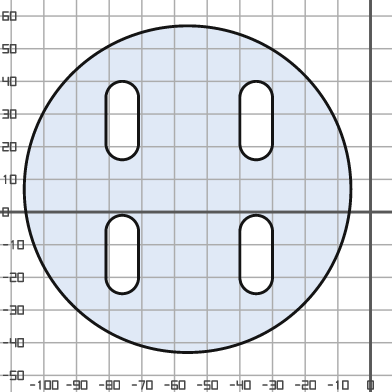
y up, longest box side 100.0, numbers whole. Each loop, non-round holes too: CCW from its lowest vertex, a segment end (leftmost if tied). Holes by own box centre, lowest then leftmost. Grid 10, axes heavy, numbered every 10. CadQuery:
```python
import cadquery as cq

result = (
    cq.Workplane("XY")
    .moveTo(-56.0, 7.0)
    .circle(50.0)
    .moveTo(-81.0, -20.0)
    .threePointArc((-76.0, -25.0), (-71.0, -20.0))
    .lineTo(-71.0, -6.0)
    .threePointArc((-76.0, -1.0), (-81.0, -6.0))
    .close()
    .moveTo(-40.0, -20.0)
    .threePointArc((-35.0, -25.0), (-30.0, -20.0))
    .lineTo(-30.0, -6.0)
    .threePointArc((-35.0, -1.0), (-40.0, -6.0))
    .close()
    .moveTo(-81.0, 21.0)
    .threePointArc((-76.0, 16.0), (-71.0, 21.0))
    .lineTo(-71.0, 35.0)
    .threePointArc((-76.0, 40.0), (-81.0, 35.0))
    .close()
    .moveTo(-40.0, 21.0)
    .threePointArc((-35.0, 16.0), (-30.0, 21.0))
    .lineTo(-30.0, 35.0)
    .threePointArc((-35.0, 40.0), (-40.0, 35.0))
    .close()
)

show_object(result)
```